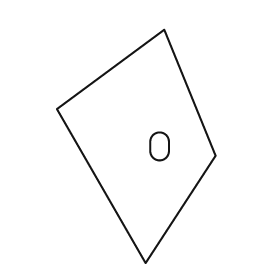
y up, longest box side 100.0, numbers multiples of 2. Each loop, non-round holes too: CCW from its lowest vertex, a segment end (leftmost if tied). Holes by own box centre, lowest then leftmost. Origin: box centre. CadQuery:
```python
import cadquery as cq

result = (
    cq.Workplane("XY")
    .moveTo(4.0, -50.0)
    .lineTo(34.0, -4.0)
    .lineTo(12.0, 50.0)
    .lineTo(-34.0, 16.0)
    .close()
    .moveTo(6.0, -2.0)
    .threePointArc((10.0, -6.0), (14.0, -2.0))
    .lineTo(14.0, 2.0)
    .threePointArc((10.0, 6.0), (6.0, 2.0))
    .close()
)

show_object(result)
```